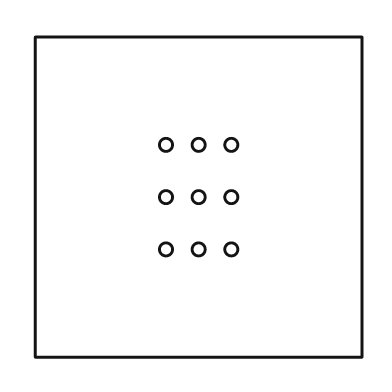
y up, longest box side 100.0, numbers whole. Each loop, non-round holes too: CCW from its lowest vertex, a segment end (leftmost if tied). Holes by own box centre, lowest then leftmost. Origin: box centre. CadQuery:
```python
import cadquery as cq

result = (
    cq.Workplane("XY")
    .moveTo(-50.0, -49.0)
    .lineTo(50.0, -49.0)
    .lineTo(50.0, 49.0)
    .lineTo(-50.0, 49.0)
    .close()
    .moveTo(-10.0, -16.0)
    .circle(2.0)
    .moveTo(0.0, -16.0)
    .circle(2.0)
    .moveTo(10.0, -16.0)
    .circle(2.0)
    .moveTo(-10.0, 0.0)
    .circle(2.0)
    .moveTo(0.0, 0.0)
    .circle(2.0)
    .moveTo(10.0, 0.0)
    .circle(2.0)
    .moveTo(-10.0, 16.0)
    .circle(2.0)
    .moveTo(0.0, 16.0)
    .circle(2.0)
    .moveTo(10.0, 16.0)
    .circle(2.0)
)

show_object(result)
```